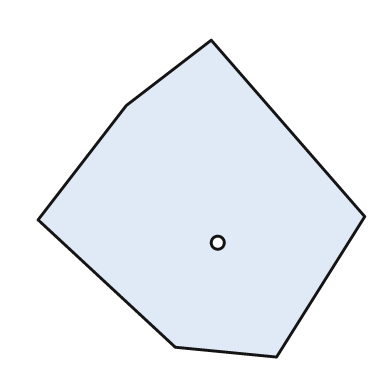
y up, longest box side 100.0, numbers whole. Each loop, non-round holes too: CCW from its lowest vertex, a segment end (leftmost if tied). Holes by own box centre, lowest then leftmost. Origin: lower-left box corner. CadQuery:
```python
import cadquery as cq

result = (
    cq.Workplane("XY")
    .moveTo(73.0, 0.0)
    .lineTo(100.0, 43.0)
    .lineTo(53.0, 97.0)
    .lineTo(27.0, 77.0)
    .lineTo(0.0, 42.0)
    .lineTo(42.0, 3.0)
    .close()
    .moveTo(55.0, 35.0)
    .circle(2.0)
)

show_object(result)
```